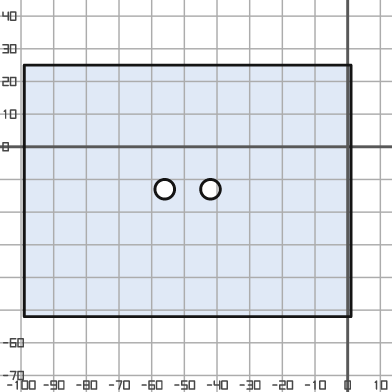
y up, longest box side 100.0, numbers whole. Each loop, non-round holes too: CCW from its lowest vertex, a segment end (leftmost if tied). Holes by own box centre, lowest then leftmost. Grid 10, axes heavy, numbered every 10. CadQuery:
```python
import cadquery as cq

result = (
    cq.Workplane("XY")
    .moveTo(-99.0, -52.0)
    .lineTo(1.0, -52.0)
    .lineTo(1.0, 25.0)
    .lineTo(-99.0, 25.0)
    .close()
    .moveTo(-56.0, -13.0)
    .circle(3.0)
    .moveTo(-42.0, -13.0)
    .circle(3.0)
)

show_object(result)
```